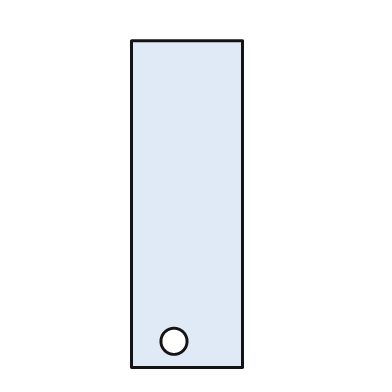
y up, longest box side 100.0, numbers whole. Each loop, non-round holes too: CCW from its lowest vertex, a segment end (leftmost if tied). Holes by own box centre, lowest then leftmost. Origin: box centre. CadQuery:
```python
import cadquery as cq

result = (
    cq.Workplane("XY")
    .moveTo(-17.0, -50.0)
    .lineTo(17.0, -50.0)
    .lineTo(17.0, 50.0)
    .lineTo(-17.0, 50.0)
    .close()
    .moveTo(-4.0, -42.0)
    .circle(4.0)
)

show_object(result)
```